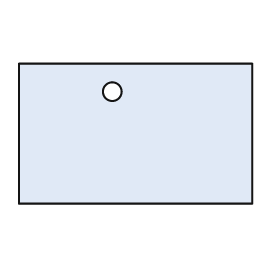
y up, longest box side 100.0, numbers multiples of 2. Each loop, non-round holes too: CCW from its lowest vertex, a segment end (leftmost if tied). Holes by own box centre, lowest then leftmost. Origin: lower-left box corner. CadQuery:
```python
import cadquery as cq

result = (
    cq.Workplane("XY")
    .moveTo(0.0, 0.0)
    .lineTo(100.0, 0.0)
    .lineTo(100.0, 60.0)
    .lineTo(0.0, 60.0)
    .close()
    .moveTo(40.0, 48.0)
    .circle(4.0)
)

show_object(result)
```